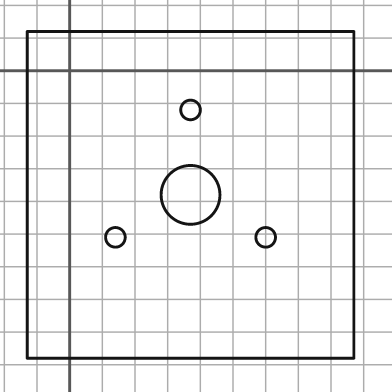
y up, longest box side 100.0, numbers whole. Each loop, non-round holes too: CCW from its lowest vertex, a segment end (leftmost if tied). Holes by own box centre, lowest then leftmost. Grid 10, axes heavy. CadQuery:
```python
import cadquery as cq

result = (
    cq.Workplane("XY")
    .moveTo(-13.0, -88.0)
    .lineTo(87.0, -88.0)
    .lineTo(87.0, 12.0)
    .lineTo(-13.0, 12.0)
    .close()
    .moveTo(14.0, -51.0)
    .circle(3.0)
    .moveTo(60.0, -51.0)
    .circle(3.0)
    .moveTo(37.0, -38.0)
    .circle(9.0)
    .moveTo(37.0, -12.0)
    .circle(3.0)
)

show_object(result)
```